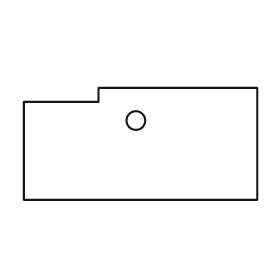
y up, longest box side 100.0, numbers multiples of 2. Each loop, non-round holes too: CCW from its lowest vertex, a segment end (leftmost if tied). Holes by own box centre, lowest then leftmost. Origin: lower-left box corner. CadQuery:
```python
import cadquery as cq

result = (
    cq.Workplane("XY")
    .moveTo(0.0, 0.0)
    .lineTo(100.0, 0.0)
    .lineTo(100.0, 48.0)
    .lineTo(32.0, 48.0)
    .lineTo(32.0, 42.0)
    .lineTo(0.0, 42.0)
    .close()
    .moveTo(48.0, 34.0)
    .circle(4.0)
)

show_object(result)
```